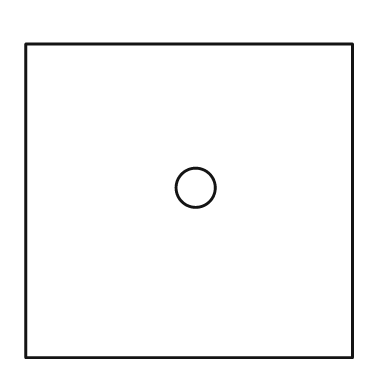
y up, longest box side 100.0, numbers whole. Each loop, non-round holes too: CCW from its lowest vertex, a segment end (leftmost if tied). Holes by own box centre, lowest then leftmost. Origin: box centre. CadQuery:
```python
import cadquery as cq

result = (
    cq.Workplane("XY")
    .moveTo(-50.0, -48.0)
    .lineTo(50.0, -48.0)
    .lineTo(50.0, 48.0)
    .lineTo(-50.0, 48.0)
    .close()
    .moveTo(2.0, 4.0)
    .circle(6.0)
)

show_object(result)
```